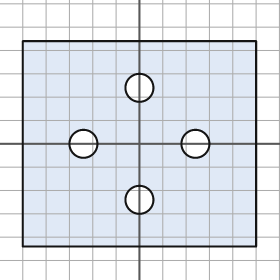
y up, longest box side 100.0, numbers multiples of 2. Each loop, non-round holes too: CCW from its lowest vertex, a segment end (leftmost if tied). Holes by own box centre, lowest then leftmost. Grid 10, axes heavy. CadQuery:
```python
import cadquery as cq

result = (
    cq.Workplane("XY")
    .moveTo(-50.0, -44.0)
    .lineTo(50.0, -44.0)
    .lineTo(50.0, 44.0)
    .lineTo(-50.0, 44.0)
    .close()
    .moveTo(0.0, -24.0)
    .circle(6.0)
    .moveTo(-24.0, 0.0)
    .circle(6.0)
    .moveTo(24.0, 0.0)
    .circle(6.0)
    .moveTo(0.0, 24.0)
    .circle(6.0)
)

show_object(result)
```